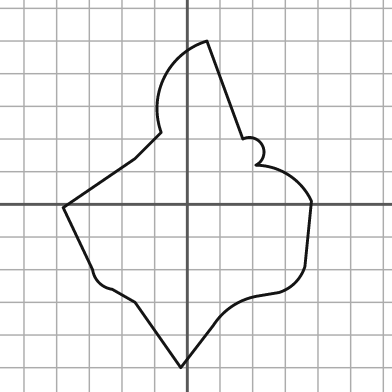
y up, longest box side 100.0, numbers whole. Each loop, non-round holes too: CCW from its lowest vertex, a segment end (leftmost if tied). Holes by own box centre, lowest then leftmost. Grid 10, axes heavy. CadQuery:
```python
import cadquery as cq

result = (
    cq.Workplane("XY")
    .moveTo(-2.0, -50.0)
    .lineTo(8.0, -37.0)
    .threePointArc((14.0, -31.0), (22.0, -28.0))
    .lineTo(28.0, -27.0)
    .threePointArc((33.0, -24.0), (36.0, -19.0))
    .lineTo(38.0, 1.0)
    .threePointArc((31.0, 9.0), (21.0, 12.0))
    .threePointArc((23.0, 18.0), (17.0, 20.0))
    .lineTo(6.0, 50.0)
    .threePointArc((-7.0, 39.0), (-8.0, 22.0))
    .lineTo(-16.0, 14.0)
    .lineTo(-38.0, -1.0)
    .lineTo(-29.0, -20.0)
    .threePointArc((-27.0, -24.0), (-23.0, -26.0))
    .lineTo(-16.0, -30.0)
    .close()
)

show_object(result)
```